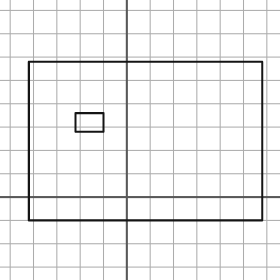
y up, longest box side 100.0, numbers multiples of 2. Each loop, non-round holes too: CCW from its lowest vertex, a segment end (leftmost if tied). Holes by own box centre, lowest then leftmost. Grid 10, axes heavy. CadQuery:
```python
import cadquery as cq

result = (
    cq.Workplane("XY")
    .moveTo(-42.0, -10.0)
    .lineTo(58.0, -10.0)
    .lineTo(58.0, 58.0)
    .lineTo(-42.0, 58.0)
    .close()
    .moveTo(-22.0, 28.0)
    .lineTo(-10.0, 28.0)
    .lineTo(-10.0, 36.0)
    .lineTo(-22.0, 36.0)
    .close()
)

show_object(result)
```